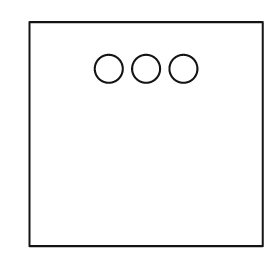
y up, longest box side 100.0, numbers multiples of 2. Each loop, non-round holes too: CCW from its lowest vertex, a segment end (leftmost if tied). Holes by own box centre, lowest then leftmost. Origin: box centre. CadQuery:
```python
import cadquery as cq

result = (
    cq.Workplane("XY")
    .moveTo(-50.0, -48.0)
    .lineTo(50.0, -48.0)
    .lineTo(50.0, 48.0)
    .lineTo(-50.0, 48.0)
    .close()
    .moveTo(-16.0, 28.0)
    .circle(6.0)
    .moveTo(0.0, 28.0)
    .circle(6.0)
    .moveTo(16.0, 28.0)
    .circle(6.0)
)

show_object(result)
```